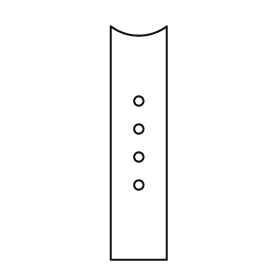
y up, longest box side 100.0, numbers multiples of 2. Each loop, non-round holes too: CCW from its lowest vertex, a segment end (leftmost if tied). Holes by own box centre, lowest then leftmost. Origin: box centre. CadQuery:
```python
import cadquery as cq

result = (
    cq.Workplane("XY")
    .moveTo(-12.0, -50.0)
    .lineTo(12.0, -50.0)
    .lineTo(12.0, 50.0)
    .threePointArc((0.0, 46.0), (-12.0, 50.0))
    .close()
    .moveTo(0.0, -18.0)
    .circle(2.0)
    .moveTo(0.0, -6.0)
    .circle(2.0)
    .moveTo(0.0, 6.0)
    .circle(2.0)
    .moveTo(0.0, 18.0)
    .circle(2.0)
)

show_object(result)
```